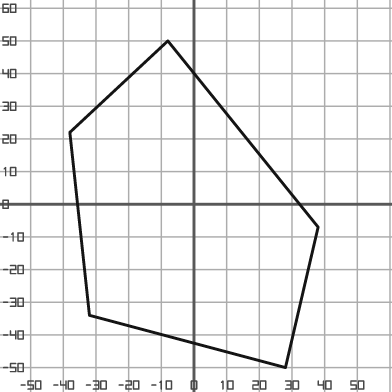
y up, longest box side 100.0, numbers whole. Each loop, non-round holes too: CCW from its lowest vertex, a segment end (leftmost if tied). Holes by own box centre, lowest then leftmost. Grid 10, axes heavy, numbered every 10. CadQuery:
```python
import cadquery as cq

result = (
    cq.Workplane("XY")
    .moveTo(28.0, -50.0)
    .lineTo(38.0, -7.0)
    .lineTo(-8.0, 50.0)
    .lineTo(-38.0, 22.0)
    .lineTo(-32.0, -34.0)
    .close()
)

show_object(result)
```